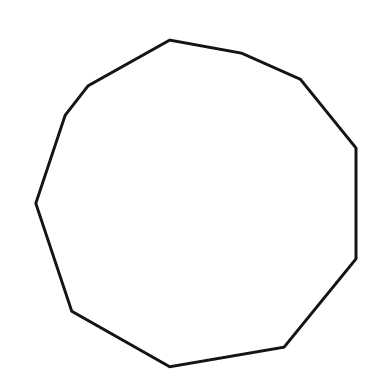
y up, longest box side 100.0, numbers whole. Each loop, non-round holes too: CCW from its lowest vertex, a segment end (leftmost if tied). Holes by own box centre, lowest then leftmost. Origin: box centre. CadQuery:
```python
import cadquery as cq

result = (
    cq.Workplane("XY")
    .moveTo(-8.0, -50.0)
    .lineTo(27.0, -44.0)
    .lineTo(49.0, -17.0)
    .lineTo(49.0, 17.0)
    .lineTo(32.0, 38.0)
    .lineTo(14.0, 46.0)
    .lineTo(-8.0, 50.0)
    .lineTo(-33.0, 36.0)
    .lineTo(-40.0, 27.0)
    .lineTo(-49.0, 0.0)
    .lineTo(-38.0, -33.0)
    .close()
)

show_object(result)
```